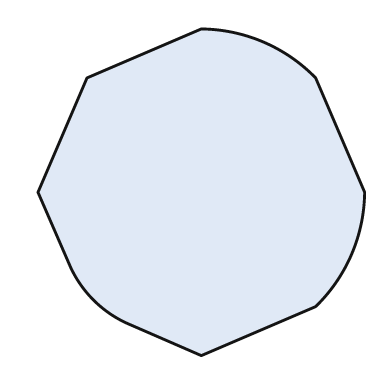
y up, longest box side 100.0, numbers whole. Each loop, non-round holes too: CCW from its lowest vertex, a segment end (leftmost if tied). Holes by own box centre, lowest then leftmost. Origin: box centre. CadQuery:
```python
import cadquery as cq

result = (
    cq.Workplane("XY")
    .moveTo(0.0, -50.0)
    .lineTo(35.0, -35.0)
    .threePointArc((46.0, -19.0), (50.0, 0.0))
    .lineTo(35.0, 35.0)
    .threePointArc((19.0, 46.0), (0.0, 50.0))
    .lineTo(-35.0, 35.0)
    .lineTo(-50.0, 0.0)
    .lineTo(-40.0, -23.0)
    .threePointArc((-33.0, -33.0), (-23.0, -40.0))
    .close()
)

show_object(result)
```